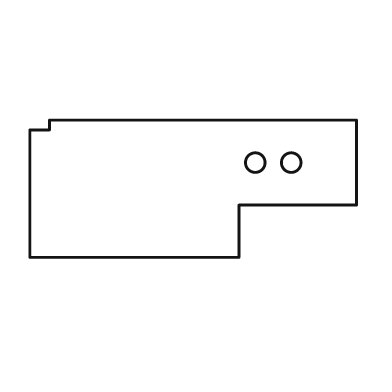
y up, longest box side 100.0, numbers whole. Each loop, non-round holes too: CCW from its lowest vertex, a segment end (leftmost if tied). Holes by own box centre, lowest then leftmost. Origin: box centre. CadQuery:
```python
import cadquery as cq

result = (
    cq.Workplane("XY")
    .moveTo(-50.0, -21.0)
    .lineTo(14.0, -21.0)
    .lineTo(14.0, -5.0)
    .lineTo(50.0, -5.0)
    .lineTo(50.0, 21.0)
    .lineTo(-44.0, 21.0)
    .lineTo(-44.0, 18.0)
    .lineTo(-50.0, 18.0)
    .close()
    .moveTo(19.0, 8.0)
    .circle(3.0)
    .moveTo(30.0, 8.0)
    .circle(3.0)
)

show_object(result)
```